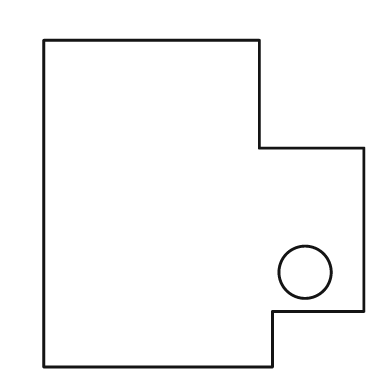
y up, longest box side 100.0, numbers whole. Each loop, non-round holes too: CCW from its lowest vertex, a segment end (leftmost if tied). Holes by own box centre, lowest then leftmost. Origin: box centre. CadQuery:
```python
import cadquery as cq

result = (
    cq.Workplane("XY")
    .moveTo(-49.0, -50.0)
    .lineTo(21.0, -50.0)
    .lineTo(21.0, -33.0)
    .lineTo(49.0, -33.0)
    .lineTo(49.0, 17.0)
    .lineTo(17.0, 17.0)
    .lineTo(17.0, 50.0)
    .lineTo(-49.0, 50.0)
    .close()
    .moveTo(31.0, -21.0)
    .circle(8.0)
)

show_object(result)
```